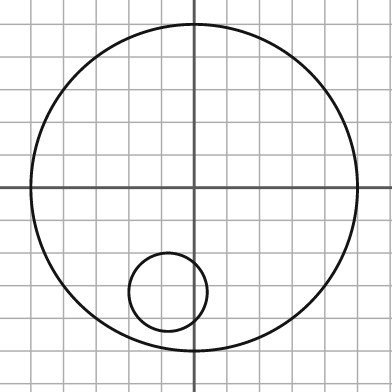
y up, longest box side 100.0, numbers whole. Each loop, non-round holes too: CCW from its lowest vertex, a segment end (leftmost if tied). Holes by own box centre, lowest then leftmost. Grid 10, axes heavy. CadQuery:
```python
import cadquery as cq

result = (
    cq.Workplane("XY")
    .moveTo(0.0, 0.0)
    .circle(50.0)
    .moveTo(-8.0, -32.0)
    .circle(12.0)
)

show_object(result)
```